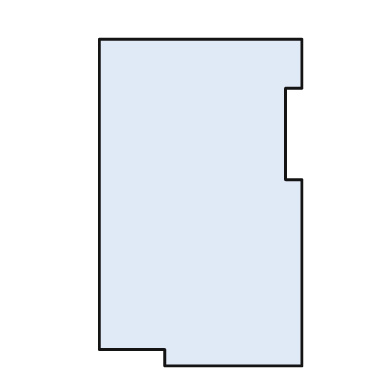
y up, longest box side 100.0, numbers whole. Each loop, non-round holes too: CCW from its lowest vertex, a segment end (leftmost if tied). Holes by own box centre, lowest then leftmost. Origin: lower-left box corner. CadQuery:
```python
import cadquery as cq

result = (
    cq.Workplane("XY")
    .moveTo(20.0, 0.0)
    .lineTo(62.0, 0.0)
    .lineTo(62.0, 57.0)
    .lineTo(57.0, 57.0)
    .lineTo(57.0, 85.0)
    .lineTo(62.0, 85.0)
    .lineTo(62.0, 100.0)
    .lineTo(0.0, 100.0)
    .lineTo(0.0, 5.0)
    .lineTo(20.0, 5.0)
    .close()
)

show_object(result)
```